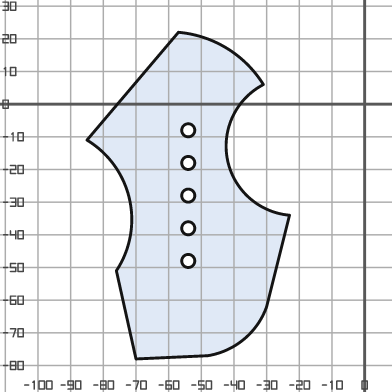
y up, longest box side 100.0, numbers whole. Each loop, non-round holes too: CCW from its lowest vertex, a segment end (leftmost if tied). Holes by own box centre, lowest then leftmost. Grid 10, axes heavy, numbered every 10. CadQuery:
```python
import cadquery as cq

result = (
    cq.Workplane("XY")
    .moveTo(-70.0, -78.0)
    .lineTo(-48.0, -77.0)
    .threePointArc((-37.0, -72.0), (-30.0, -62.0))
    .lineTo(-23.0, -34.0)
    .threePointArc((-42.0, -17.0), (-31.0, 6.0))
    .threePointArc((-42.0, 17.0), (-57.0, 22.0))
    .lineTo(-85.0, -11.0)
    .threePointArc((-72.0, -29.0), (-76.0, -51.0))
    .close()
    .moveTo(-54.0, -48.0)
    .circle(2.0)
    .moveTo(-54.0, -38.0)
    .circle(2.0)
    .moveTo(-54.0, -28.0)
    .circle(2.0)
    .moveTo(-54.0, -18.0)
    .circle(2.0)
    .moveTo(-54.0, -8.0)
    .circle(2.0)
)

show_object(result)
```